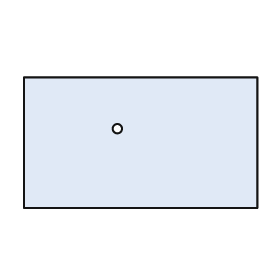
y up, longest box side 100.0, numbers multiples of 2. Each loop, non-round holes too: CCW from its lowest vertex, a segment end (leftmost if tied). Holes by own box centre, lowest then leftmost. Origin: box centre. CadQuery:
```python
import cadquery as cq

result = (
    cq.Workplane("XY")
    .moveTo(-50.0, -28.0)
    .lineTo(50.0, -28.0)
    .lineTo(50.0, 28.0)
    .lineTo(-50.0, 28.0)
    .close()
    .moveTo(-10.0, 6.0)
    .circle(2.0)
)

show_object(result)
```